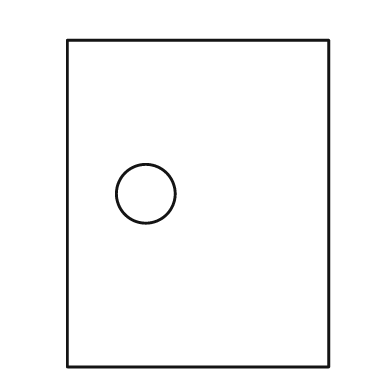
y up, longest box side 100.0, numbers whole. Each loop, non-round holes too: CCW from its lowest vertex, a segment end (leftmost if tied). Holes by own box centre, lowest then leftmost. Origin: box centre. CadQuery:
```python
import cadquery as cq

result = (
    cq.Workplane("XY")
    .moveTo(-40.0, -50.0)
    .lineTo(40.0, -50.0)
    .lineTo(40.0, 50.0)
    .lineTo(-40.0, 50.0)
    .close()
    .moveTo(-16.0, 3.0)
    .circle(9.0)
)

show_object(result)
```